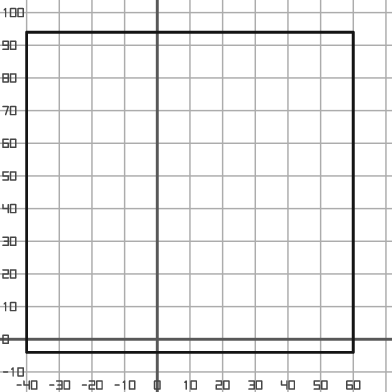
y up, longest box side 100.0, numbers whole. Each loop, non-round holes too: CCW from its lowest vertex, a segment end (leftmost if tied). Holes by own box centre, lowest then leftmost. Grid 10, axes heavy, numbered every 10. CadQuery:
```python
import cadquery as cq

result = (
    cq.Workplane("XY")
    .moveTo(-40.0, -4.0)
    .lineTo(60.0, -4.0)
    .lineTo(60.0, 94.0)
    .lineTo(-40.0, 94.0)
    .close()
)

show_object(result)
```